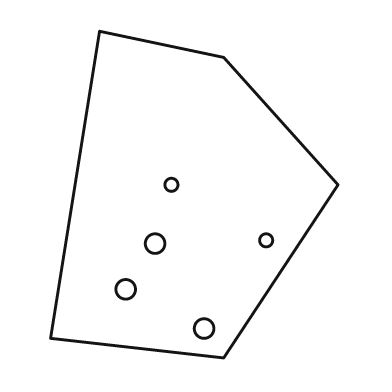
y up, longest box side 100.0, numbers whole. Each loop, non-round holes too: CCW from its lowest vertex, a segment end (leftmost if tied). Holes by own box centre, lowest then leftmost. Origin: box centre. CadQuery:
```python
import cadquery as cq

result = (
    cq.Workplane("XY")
    .moveTo(9.0, -50.0)
    .lineTo(44.0, 3.0)
    .lineTo(9.0, 42.0)
    .lineTo(-29.0, 50.0)
    .lineTo(-44.0, -44.0)
    .close()
    .moveTo(3.0, -41.0)
    .circle(3.0)
    .moveTo(-21.0, -29.0)
    .circle(3.0)
    .moveTo(-12.0, -15.0)
    .circle(3.0)
    .moveTo(22.0, -14.0)
    .circle(2.0)
    .moveTo(-7.0, 3.0)
    .circle(2.0)
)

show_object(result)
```